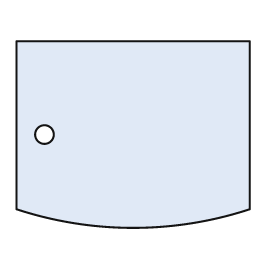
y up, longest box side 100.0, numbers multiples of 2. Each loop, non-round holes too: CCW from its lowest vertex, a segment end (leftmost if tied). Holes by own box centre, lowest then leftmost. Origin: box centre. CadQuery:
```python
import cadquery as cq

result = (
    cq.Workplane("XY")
    .moveTo(-50.0, -32.0)
    .threePointArc((0.0, -40.0), (50.0, -32.0))
    .lineTo(50.0, 40.0)
    .lineTo(-50.0, 40.0)
    .close()
    .moveTo(-38.0, 0.0)
    .circle(4.0)
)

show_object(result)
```